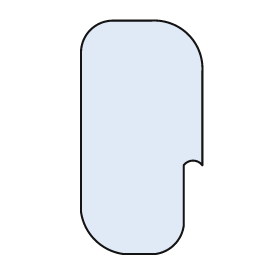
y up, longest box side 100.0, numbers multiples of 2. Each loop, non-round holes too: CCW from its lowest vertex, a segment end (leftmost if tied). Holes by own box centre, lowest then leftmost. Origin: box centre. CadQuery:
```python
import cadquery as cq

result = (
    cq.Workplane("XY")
    .moveTo(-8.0, -50.0)
    .lineTo(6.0, -50.0)
    .threePointArc((14.0, -46.0), (18.0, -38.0))
    .lineTo(18.0, -12.0)
    .threePointArc((22.0, -10.0), (26.0, -12.0))
    .lineTo(26.0, 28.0)
    .threePointArc((20.0, 44.0), (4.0, 50.0))
    .lineTo(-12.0, 50.0)
    .threePointArc((-22.0, 46.0), (-26.0, 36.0))
    .lineTo(-26.0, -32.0)
    .threePointArc((-20.0, -44.0), (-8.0, -50.0))
    .close()
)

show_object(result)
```